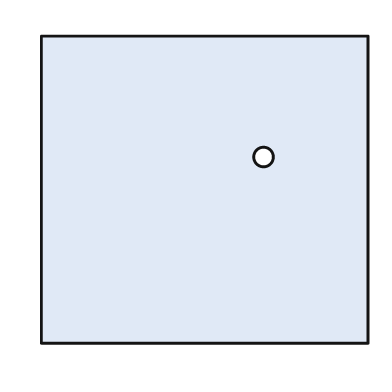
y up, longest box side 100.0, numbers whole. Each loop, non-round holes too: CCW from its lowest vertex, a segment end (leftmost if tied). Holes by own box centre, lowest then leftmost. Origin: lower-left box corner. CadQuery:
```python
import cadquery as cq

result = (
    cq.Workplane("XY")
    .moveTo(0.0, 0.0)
    .lineTo(100.0, 0.0)
    .lineTo(100.0, 94.0)
    .lineTo(0.0, 94.0)
    .close()
    .moveTo(68.0, 57.0)
    .circle(3.0)
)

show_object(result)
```